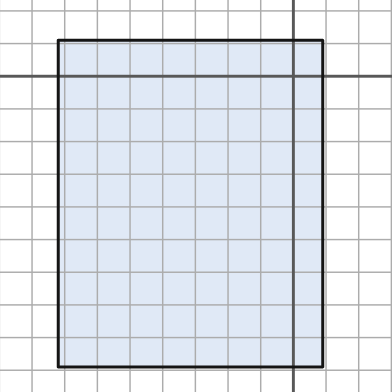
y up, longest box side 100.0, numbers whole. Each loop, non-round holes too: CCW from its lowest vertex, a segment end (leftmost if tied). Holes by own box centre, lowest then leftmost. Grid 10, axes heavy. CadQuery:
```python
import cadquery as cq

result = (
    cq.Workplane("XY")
    .moveTo(-72.0, -89.0)
    .lineTo(9.0, -89.0)
    .lineTo(9.0, 11.0)
    .lineTo(-72.0, 11.0)
    .close()
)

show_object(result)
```